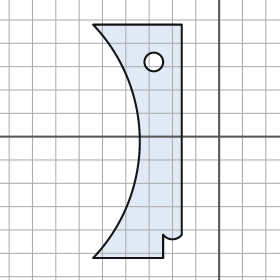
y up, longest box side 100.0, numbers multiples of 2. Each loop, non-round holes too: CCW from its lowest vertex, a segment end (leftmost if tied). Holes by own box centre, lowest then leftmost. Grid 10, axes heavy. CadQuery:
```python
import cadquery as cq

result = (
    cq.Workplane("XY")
    .moveTo(-54.0, -52.0)
    .lineTo(-24.0, -52.0)
    .lineTo(-24.0, -42.0)
    .threePointArc((-20.0, -44.0), (-16.0, -42.0))
    .lineTo(-16.0, 48.0)
    .lineTo(-54.0, 48.0)
    .threePointArc((-34.0, -2.0), (-54.0, -52.0))
    .close()
    .moveTo(-28.0, 32.0)
    .circle(4.0)
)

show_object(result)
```